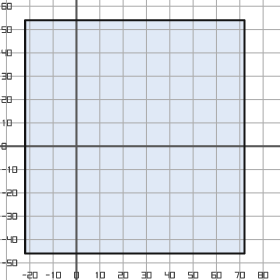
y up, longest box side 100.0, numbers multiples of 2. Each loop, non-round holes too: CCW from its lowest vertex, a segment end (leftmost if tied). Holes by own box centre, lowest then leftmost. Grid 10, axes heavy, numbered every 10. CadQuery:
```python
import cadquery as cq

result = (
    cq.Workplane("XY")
    .moveTo(-22.0, -46.0)
    .lineTo(72.0, -46.0)
    .lineTo(72.0, 54.0)
    .lineTo(-22.0, 54.0)
    .close()
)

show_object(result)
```